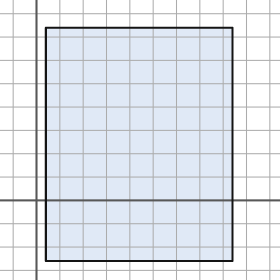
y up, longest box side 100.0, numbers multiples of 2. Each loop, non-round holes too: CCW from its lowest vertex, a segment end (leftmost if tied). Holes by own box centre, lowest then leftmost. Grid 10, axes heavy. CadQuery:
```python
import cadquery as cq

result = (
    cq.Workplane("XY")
    .moveTo(4.0, -26.0)
    .lineTo(84.0, -26.0)
    .lineTo(84.0, 74.0)
    .lineTo(4.0, 74.0)
    .close()
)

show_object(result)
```